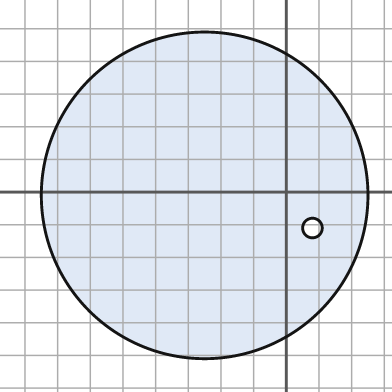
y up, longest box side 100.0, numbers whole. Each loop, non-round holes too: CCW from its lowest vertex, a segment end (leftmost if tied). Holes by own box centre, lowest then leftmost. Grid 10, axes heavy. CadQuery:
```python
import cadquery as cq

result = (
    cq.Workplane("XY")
    .moveTo(-25.0, -1.0)
    .circle(50.0)
    .moveTo(8.0, -11.0)
    .circle(3.0)
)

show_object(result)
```